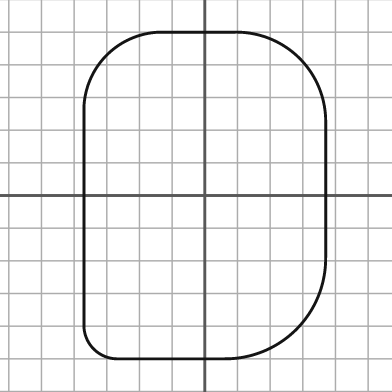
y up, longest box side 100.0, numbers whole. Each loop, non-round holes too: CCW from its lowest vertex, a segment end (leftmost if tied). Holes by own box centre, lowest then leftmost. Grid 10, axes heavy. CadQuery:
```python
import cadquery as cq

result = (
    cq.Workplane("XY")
    .moveTo(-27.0, -50.0)
    .lineTo(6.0, -50.0)
    .threePointArc((28.0, -41.0), (37.0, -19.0))
    .lineTo(37.0, 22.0)
    .threePointArc((29.0, 42.0), (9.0, 50.0))
    .lineTo(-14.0, 50.0)
    .threePointArc((-30.0, 43.0), (-37.0, 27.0))
    .lineTo(-37.0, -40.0)
    .threePointArc((-34.0, -47.0), (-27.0, -50.0))
    .close()
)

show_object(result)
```